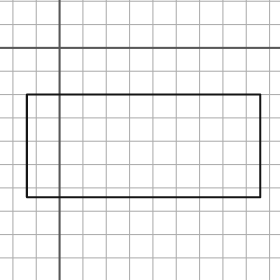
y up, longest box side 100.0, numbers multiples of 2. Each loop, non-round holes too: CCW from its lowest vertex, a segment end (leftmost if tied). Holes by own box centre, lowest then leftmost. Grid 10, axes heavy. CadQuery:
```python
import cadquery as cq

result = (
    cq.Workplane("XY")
    .moveTo(-14.0, -64.0)
    .lineTo(86.0, -64.0)
    .lineTo(86.0, -20.0)
    .lineTo(-14.0, -20.0)
    .close()
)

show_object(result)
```